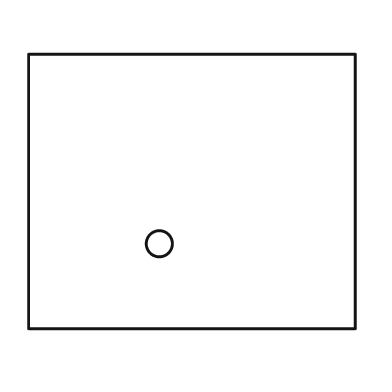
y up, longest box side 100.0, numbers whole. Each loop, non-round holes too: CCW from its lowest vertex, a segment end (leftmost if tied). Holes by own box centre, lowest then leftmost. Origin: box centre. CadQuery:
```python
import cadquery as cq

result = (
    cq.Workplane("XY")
    .moveTo(-50.0, -42.0)
    .lineTo(50.0, -42.0)
    .lineTo(50.0, 42.0)
    .lineTo(-50.0, 42.0)
    .close()
    .moveTo(-10.0, -16.0)
    .circle(4.0)
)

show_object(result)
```